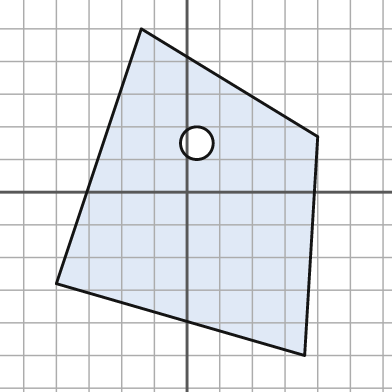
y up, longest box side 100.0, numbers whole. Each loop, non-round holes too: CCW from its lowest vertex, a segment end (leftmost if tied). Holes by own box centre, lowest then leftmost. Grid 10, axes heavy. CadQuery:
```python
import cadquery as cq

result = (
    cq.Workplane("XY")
    .moveTo(36.0, -50.0)
    .lineTo(40.0, 17.0)
    .lineTo(-14.0, 50.0)
    .lineTo(-40.0, -28.0)
    .close()
    .moveTo(3.0, 15.0)
    .circle(5.0)
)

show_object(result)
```